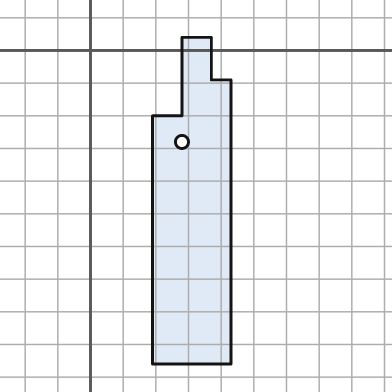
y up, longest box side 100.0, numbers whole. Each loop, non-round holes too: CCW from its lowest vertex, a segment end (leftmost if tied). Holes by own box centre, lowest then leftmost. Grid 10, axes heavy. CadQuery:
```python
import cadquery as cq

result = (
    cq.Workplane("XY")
    .moveTo(19.0, -96.0)
    .lineTo(43.0, -96.0)
    .lineTo(43.0, -9.0)
    .lineTo(37.0, -9.0)
    .lineTo(37.0, 4.0)
    .lineTo(28.0, 4.0)
    .lineTo(28.0, -20.0)
    .lineTo(19.0, -20.0)
    .close()
    .moveTo(28.0, -28.0)
    .circle(2.0)
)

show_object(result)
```